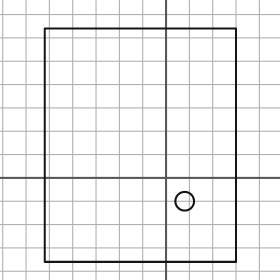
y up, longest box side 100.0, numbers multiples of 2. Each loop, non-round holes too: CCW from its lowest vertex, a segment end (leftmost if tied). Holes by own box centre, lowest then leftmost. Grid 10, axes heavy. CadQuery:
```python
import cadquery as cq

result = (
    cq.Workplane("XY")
    .moveTo(-52.0, -36.0)
    .lineTo(30.0, -36.0)
    .lineTo(30.0, 64.0)
    .lineTo(-52.0, 64.0)
    .close()
    .moveTo(8.0, -10.0)
    .circle(4.0)
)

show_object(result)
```